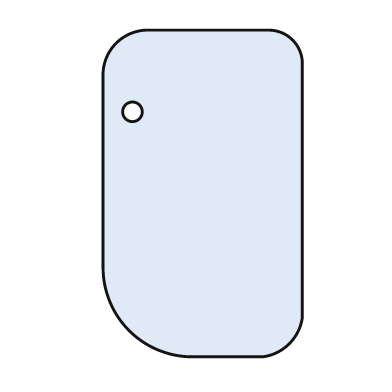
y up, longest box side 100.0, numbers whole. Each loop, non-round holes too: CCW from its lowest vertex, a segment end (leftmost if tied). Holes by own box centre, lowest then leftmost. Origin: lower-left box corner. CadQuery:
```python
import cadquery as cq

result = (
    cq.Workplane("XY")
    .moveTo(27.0, 0.0)
    .lineTo(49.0, 0.0)
    .threePointArc((57.0, 4.0), (61.0, 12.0))
    .lineTo(61.0, 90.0)
    .threePointArc((58.0, 97.0), (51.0, 100.0))
    .lineTo(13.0, 100.0)
    .threePointArc((4.0, 96.0), (0.0, 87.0))
    .lineTo(0.0, 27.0)
    .threePointArc((8.0, 8.0), (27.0, 0.0))
    .close()
    .moveTo(9.0, 75.0)
    .circle(3.0)
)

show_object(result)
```